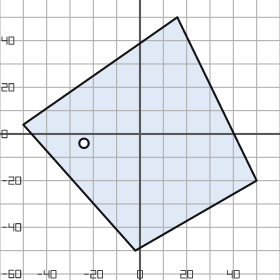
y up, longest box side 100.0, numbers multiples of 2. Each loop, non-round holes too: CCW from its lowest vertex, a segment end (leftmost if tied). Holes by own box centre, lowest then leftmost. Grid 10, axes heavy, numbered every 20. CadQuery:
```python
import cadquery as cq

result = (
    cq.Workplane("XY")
    .moveTo(-2.0, -50.0)
    .lineTo(50.0, -20.0)
    .lineTo(16.0, 50.0)
    .lineTo(-50.0, 4.0)
    .close()
    .moveTo(-24.0, -4.0)
    .circle(2.0)
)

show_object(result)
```